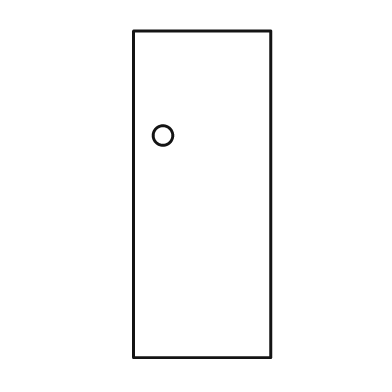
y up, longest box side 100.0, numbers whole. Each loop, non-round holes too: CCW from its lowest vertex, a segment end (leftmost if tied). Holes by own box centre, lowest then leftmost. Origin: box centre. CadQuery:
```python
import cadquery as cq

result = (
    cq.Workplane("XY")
    .moveTo(-21.0, -50.0)
    .lineTo(21.0, -50.0)
    .lineTo(21.0, 50.0)
    .lineTo(-21.0, 50.0)
    .close()
    .moveTo(-12.0, 18.0)
    .circle(3.0)
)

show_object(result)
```